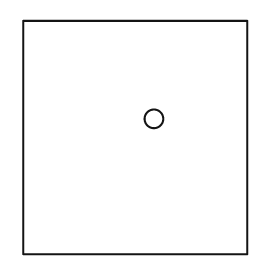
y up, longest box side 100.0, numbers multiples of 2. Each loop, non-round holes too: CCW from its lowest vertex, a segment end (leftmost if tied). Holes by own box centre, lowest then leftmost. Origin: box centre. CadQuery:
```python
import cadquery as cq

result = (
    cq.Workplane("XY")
    .moveTo(-48.0, -50.0)
    .lineTo(48.0, -50.0)
    .lineTo(48.0, 50.0)
    .lineTo(-48.0, 50.0)
    .close()
    .moveTo(8.0, 8.0)
    .circle(4.0)
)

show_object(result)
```